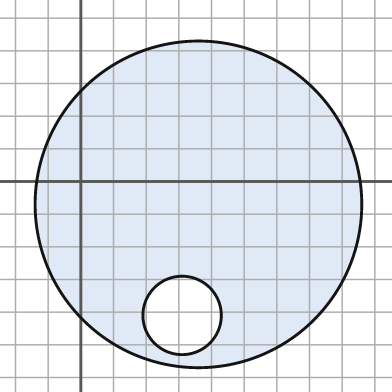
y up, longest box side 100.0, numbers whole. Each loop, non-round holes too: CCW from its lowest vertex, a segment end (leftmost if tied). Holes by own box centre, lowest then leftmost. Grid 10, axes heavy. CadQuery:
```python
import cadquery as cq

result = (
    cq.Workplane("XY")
    .moveTo(36.0, -7.0)
    .circle(50.0)
    .moveTo(31.0, -41.0)
    .circle(12.0)
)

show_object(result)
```